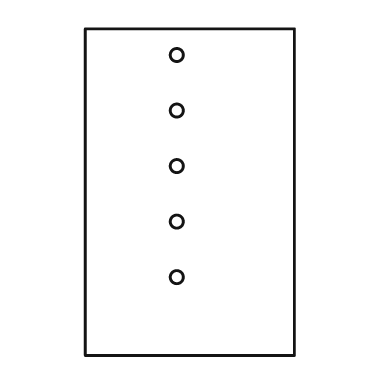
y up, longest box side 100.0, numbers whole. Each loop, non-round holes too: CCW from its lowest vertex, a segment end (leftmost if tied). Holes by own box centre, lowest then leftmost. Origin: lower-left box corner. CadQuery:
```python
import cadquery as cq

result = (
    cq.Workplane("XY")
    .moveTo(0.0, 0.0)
    .lineTo(64.0, 0.0)
    .lineTo(64.0, 100.0)
    .lineTo(0.0, 100.0)
    .close()
    .moveTo(28.0, 24.0)
    .circle(2.0)
    .moveTo(28.0, 41.0)
    .circle(2.0)
    .moveTo(28.0, 58.0)
    .circle(2.0)
    .moveTo(28.0, 75.0)
    .circle(2.0)
    .moveTo(28.0, 92.0)
    .circle(2.0)
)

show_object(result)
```